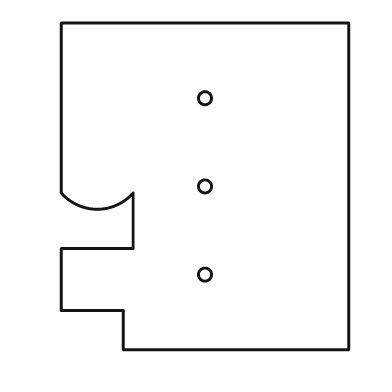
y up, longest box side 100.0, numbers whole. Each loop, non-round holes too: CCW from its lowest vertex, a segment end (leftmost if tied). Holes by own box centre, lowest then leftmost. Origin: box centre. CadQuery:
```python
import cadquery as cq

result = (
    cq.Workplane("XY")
    .moveTo(-25.0, -50.0)
    .lineTo(44.0, -50.0)
    .lineTo(44.0, 50.0)
    .lineTo(-44.0, 50.0)
    .lineTo(-44.0, -2.0)
    .threePointArc((-33.0, -7.0), (-22.0, -2.0))
    .lineTo(-22.0, -19.0)
    .lineTo(-44.0, -19.0)
    .lineTo(-44.0, -38.0)
    .lineTo(-25.0, -38.0)
    .close()
    .moveTo(0.0, -27.0)
    .circle(2.0)
    .moveTo(0.0, 0.0)
    .circle(2.0)
    .moveTo(0.0, 27.0)
    .circle(2.0)
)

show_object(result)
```